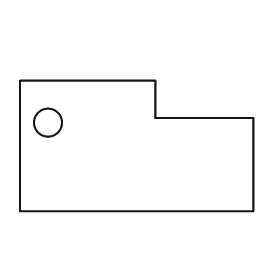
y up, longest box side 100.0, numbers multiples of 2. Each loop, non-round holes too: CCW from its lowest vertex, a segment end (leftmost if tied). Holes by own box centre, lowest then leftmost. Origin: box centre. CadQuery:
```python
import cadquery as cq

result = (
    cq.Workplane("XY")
    .moveTo(-50.0, -28.0)
    .lineTo(50.0, -28.0)
    .lineTo(50.0, 12.0)
    .lineTo(8.0, 12.0)
    .lineTo(8.0, 28.0)
    .lineTo(-50.0, 28.0)
    .close()
    .moveTo(-38.0, 10.0)
    .circle(6.0)
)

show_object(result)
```